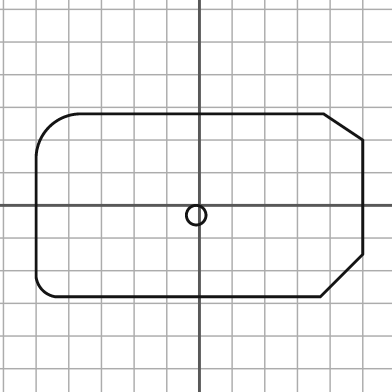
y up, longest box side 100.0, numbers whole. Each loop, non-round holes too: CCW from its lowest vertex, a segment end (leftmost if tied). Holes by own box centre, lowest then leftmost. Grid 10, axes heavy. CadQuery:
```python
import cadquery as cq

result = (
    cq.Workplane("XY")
    .moveTo(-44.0, -28.0)
    .lineTo(37.0, -28.0)
    .lineTo(50.0, -15.0)
    .lineTo(50.0, 20.0)
    .lineTo(38.0, 28.0)
    .lineTo(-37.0, 28.0)
    .threePointArc((-46.0, 24.0), (-50.0, 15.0))
    .lineTo(-50.0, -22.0)
    .threePointArc((-48.0, -26.0), (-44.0, -28.0))
    .close()
    .moveTo(-1.0, -3.0)
    .circle(3.0)
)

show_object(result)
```